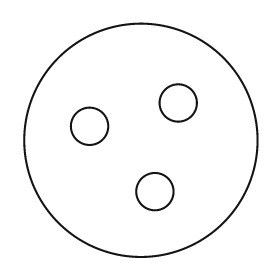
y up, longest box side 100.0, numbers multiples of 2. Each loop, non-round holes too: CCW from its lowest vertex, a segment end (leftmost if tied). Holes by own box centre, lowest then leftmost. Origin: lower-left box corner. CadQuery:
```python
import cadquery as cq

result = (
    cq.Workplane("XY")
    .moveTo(50.0, 50.0)
    .circle(50.0)
    .moveTo(56.0, 28.0)
    .circle(8.0)
    .moveTo(28.0, 56.0)
    .circle(8.0)
    .moveTo(66.0, 66.0)
    .circle(8.0)
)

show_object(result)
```